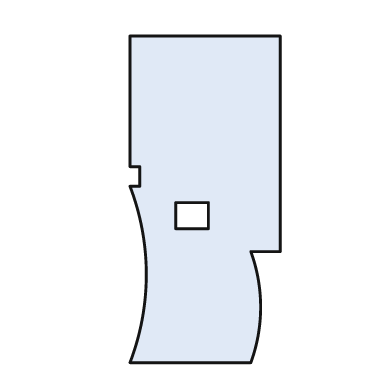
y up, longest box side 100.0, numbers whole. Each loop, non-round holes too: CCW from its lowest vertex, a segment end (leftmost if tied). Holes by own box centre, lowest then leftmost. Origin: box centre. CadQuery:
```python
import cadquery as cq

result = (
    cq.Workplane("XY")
    .moveTo(-23.0, -50.0)
    .lineTo(14.0, -50.0)
    .threePointArc((17.0, -33.0), (14.0, -16.0))
    .lineTo(23.0, -16.0)
    .lineTo(23.0, 50.0)
    .lineTo(-23.0, 50.0)
    .lineTo(-23.0, 10.0)
    .lineTo(-20.0, 10.0)
    .lineTo(-20.0, 4.0)
    .lineTo(-23.0, 4.0)
    .threePointArc((-18.0, -23.0), (-23.0, -50.0))
    .close()
    .moveTo(-9.0, -9.0)
    .lineTo(1.0, -9.0)
    .lineTo(1.0, -1.0)
    .lineTo(-9.0, -1.0)
    .close()
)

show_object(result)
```